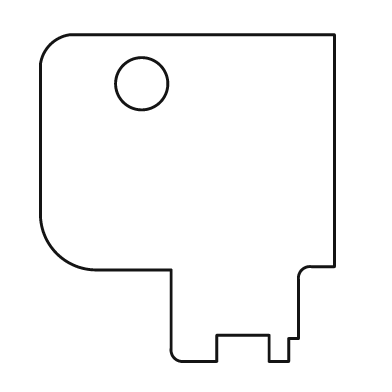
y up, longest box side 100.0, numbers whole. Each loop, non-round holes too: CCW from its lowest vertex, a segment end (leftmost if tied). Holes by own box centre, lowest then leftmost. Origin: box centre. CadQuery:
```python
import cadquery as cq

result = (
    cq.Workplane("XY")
    .moveTo(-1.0, -50.0)
    .lineTo(9.0, -50.0)
    .lineTo(9.0, -42.0)
    .lineTo(25.0, -42.0)
    .lineTo(25.0, -50.0)
    .lineTo(31.0, -50.0)
    .lineTo(31.0, -43.0)
    .lineTo(34.0, -43.0)
    .lineTo(34.0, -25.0)
    .threePointArc((35.0, -22.0), (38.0, -21.0))
    .lineTo(45.0, -21.0)
    .lineTo(45.0, 50.0)
    .lineTo(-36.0, 50.0)
    .threePointArc((-42.0, 47.0), (-45.0, 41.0))
    .lineTo(-45.0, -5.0)
    .threePointArc((-40.0, -17.0), (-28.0, -22.0))
    .lineTo(-5.0, -22.0)
    .lineTo(-5.0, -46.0)
    .threePointArc((-4.0, -49.0), (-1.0, -50.0))
    .close()
    .moveTo(-14.0, 35.0)
    .circle(8.0)
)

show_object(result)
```